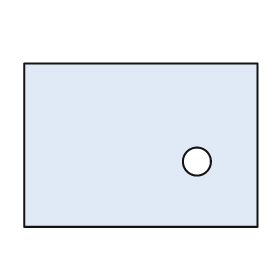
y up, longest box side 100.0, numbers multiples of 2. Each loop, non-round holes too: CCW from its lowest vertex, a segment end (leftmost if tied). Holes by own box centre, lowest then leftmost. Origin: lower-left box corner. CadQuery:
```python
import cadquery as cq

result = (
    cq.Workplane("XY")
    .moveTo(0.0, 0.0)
    .lineTo(100.0, 0.0)
    .lineTo(100.0, 70.0)
    .lineTo(0.0, 70.0)
    .close()
    .moveTo(74.0, 28.0)
    .circle(6.0)
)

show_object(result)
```